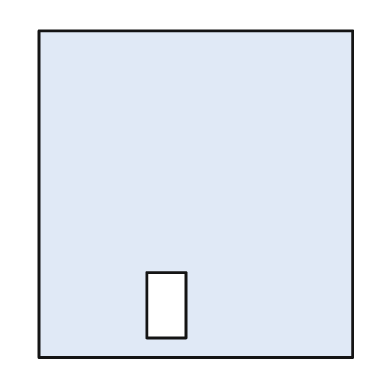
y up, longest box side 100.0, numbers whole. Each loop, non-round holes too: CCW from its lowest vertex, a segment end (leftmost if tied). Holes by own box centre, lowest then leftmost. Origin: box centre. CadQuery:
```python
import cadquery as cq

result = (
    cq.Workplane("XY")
    .moveTo(-48.0, -50.0)
    .lineTo(48.0, -50.0)
    .lineTo(48.0, 50.0)
    .lineTo(-48.0, 50.0)
    .close()
    .moveTo(-15.0, -44.0)
    .lineTo(-3.0, -44.0)
    .lineTo(-3.0, -24.0)
    .lineTo(-15.0, -24.0)
    .close()
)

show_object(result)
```